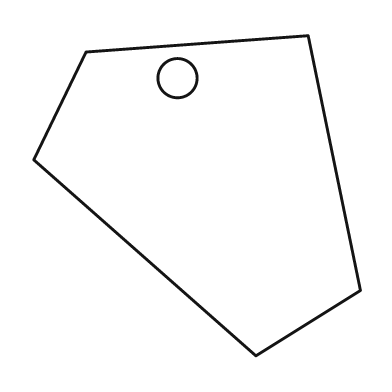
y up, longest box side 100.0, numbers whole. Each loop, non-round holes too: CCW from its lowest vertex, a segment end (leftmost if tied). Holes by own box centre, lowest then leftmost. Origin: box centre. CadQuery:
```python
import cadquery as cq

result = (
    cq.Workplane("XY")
    .moveTo(18.0, -49.0)
    .lineTo(50.0, -29.0)
    .lineTo(34.0, 49.0)
    .lineTo(-34.0, 44.0)
    .lineTo(-50.0, 11.0)
    .close()
    .moveTo(-6.0, 36.0)
    .circle(6.0)
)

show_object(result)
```